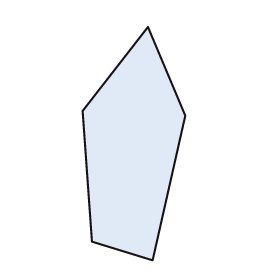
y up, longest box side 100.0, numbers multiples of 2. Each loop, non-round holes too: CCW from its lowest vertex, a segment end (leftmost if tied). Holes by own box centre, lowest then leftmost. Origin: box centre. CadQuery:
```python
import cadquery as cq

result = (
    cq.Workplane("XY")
    .moveTo(8.0, -50.0)
    .lineTo(22.0, 12.0)
    .lineTo(6.0, 50.0)
    .lineTo(-22.0, 14.0)
    .lineTo(-18.0, -42.0)
    .close()
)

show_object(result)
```